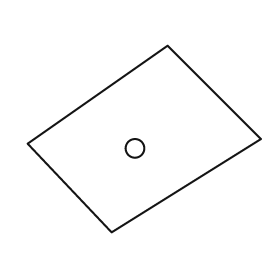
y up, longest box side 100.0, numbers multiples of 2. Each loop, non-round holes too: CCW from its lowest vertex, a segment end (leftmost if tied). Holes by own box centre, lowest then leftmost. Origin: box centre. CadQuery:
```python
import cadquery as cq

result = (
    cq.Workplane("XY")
    .moveTo(-14.0, -40.0)
    .lineTo(50.0, 0.0)
    .lineTo(10.0, 40.0)
    .lineTo(-50.0, -2.0)
    .close()
    .moveTo(-4.0, -4.0)
    .circle(4.0)
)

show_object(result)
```